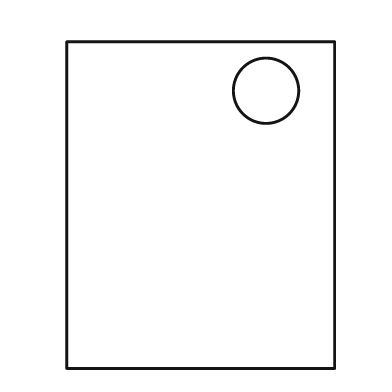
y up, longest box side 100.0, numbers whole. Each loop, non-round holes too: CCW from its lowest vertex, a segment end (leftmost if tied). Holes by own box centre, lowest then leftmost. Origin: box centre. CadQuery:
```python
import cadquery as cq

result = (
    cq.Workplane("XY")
    .moveTo(-41.0, -50.0)
    .lineTo(41.0, -50.0)
    .lineTo(41.0, 50.0)
    .lineTo(-41.0, 50.0)
    .close()
    .moveTo(20.0, 35.0)
    .circle(10.0)
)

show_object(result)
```